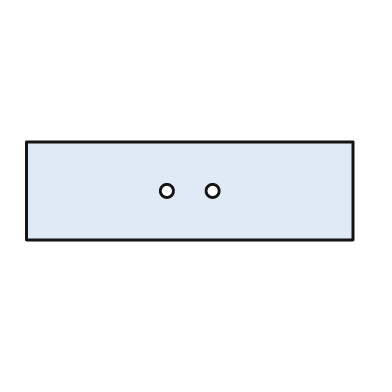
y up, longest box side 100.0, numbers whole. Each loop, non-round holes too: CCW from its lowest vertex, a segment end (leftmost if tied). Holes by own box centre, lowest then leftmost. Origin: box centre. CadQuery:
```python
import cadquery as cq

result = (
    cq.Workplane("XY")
    .moveTo(-50.0, -15.0)
    .lineTo(50.0, -15.0)
    .lineTo(50.0, 15.0)
    .lineTo(-50.0, 15.0)
    .close()
    .moveTo(-7.0, 0.0)
    .circle(2.0)
    .moveTo(7.0, 0.0)
    .circle(2.0)
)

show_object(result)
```